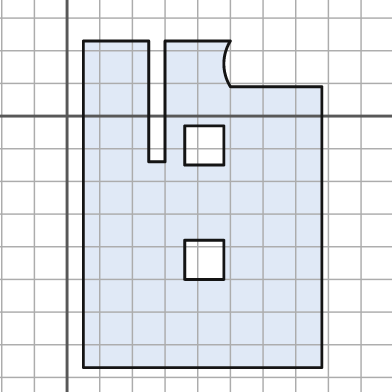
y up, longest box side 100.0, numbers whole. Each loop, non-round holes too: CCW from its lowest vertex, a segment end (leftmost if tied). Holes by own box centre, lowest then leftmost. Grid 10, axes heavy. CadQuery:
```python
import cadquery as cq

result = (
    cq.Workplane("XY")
    .moveTo(5.0, -77.0)
    .lineTo(78.0, -77.0)
    .lineTo(78.0, 9.0)
    .lineTo(50.0, 9.0)
    .threePointArc((48.0, 16.0), (50.0, 23.0))
    .lineTo(30.0, 23.0)
    .lineTo(30.0, -14.0)
    .lineTo(25.0, -14.0)
    .lineTo(25.0, 23.0)
    .lineTo(5.0, 23.0)
    .close()
    .moveTo(36.0, -50.0)
    .lineTo(48.0, -50.0)
    .lineTo(48.0, -38.0)
    .lineTo(36.0, -38.0)
    .close()
    .moveTo(36.0, -15.0)
    .lineTo(48.0, -15.0)
    .lineTo(48.0, -3.0)
    .lineTo(36.0, -3.0)
    .close()
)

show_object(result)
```